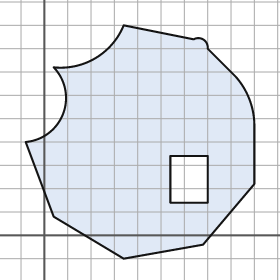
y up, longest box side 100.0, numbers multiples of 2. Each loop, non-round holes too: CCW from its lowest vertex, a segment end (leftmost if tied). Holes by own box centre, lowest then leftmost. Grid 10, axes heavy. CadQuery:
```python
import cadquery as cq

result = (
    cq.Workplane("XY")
    .moveTo(34.0, -10.0)
    .lineTo(68.0, -4.0)
    .lineTo(90.0, 22.0)
    .lineTo(90.0, 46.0)
    .threePointArc((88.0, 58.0), (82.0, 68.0))
    .lineTo(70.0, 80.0)
    .threePointArc((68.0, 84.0), (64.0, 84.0))
    .lineTo(34.0, 90.0)
    .threePointArc((22.0, 76.0), (4.0, 72.0))
    .threePointArc((8.0, 52.0), (-8.0, 40.0))
    .lineTo(4.0, 8.0)
    .close()
    .moveTo(54.0, 14.0)
    .lineTo(70.0, 14.0)
    .lineTo(70.0, 34.0)
    .lineTo(54.0, 34.0)
    .close()
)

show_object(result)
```